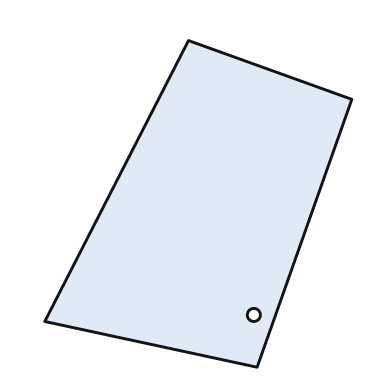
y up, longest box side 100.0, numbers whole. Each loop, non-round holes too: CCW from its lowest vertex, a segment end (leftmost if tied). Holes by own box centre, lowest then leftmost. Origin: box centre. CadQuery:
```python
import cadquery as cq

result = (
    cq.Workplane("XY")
    .moveTo(18.0, -50.0)
    .lineTo(47.0, 32.0)
    .lineTo(-3.0, 50.0)
    .lineTo(-47.0, -36.0)
    .close()
    .moveTo(17.0, -34.0)
    .circle(2.0)
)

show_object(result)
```